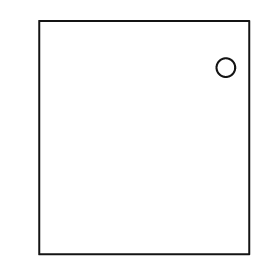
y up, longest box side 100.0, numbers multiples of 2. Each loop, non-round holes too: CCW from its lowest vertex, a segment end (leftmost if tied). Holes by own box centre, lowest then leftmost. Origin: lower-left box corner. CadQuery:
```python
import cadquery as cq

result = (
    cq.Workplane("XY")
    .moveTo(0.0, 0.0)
    .lineTo(90.0, 0.0)
    .lineTo(90.0, 100.0)
    .lineTo(0.0, 100.0)
    .close()
    .moveTo(80.0, 80.0)
    .circle(4.0)
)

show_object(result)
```